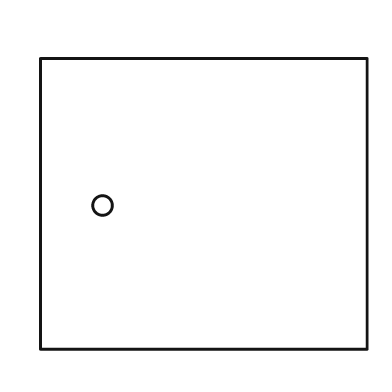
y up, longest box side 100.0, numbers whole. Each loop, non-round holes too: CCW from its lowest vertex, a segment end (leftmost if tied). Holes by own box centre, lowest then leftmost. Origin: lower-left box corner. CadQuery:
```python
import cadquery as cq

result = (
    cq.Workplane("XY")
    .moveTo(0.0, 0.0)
    .lineTo(100.0, 0.0)
    .lineTo(100.0, 89.0)
    .lineTo(0.0, 89.0)
    .close()
    .moveTo(19.0, 44.0)
    .circle(3.0)
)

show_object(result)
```